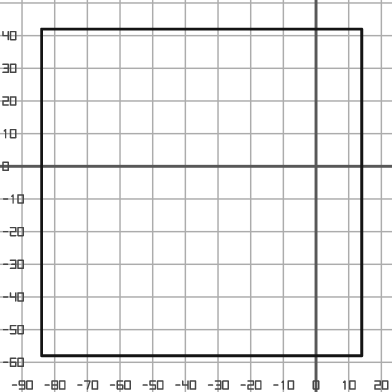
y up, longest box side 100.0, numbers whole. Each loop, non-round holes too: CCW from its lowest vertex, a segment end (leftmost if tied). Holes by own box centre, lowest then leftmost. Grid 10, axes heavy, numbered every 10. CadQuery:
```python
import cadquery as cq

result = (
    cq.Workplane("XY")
    .moveTo(-84.0, -58.0)
    .lineTo(14.0, -58.0)
    .lineTo(14.0, 42.0)
    .lineTo(-84.0, 42.0)
    .close()
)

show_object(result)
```